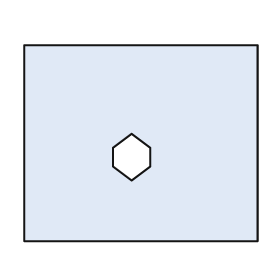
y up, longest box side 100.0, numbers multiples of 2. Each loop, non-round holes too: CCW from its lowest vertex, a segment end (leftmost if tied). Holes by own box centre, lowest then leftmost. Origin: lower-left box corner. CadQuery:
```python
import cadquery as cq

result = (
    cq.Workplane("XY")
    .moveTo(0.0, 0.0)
    .lineTo(100.0, 0.0)
    .lineTo(100.0, 84.0)
    .lineTo(0.0, 84.0)
    .close()
    .moveTo(46.0, 26.0)
    .lineTo(54.0, 32.0)
    .lineTo(54.0, 40.0)
    .lineTo(46.0, 46.0)
    .lineTo(38.0, 40.0)
    .lineTo(38.0, 32.0)
    .close()
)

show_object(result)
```